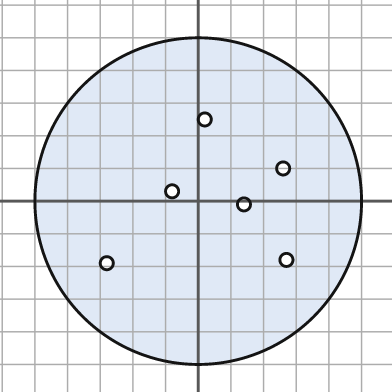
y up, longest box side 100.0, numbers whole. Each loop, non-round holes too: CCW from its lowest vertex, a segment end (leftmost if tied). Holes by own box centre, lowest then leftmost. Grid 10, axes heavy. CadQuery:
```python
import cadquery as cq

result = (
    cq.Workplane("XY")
    .moveTo(0.0, 0.0)
    .circle(50.0)
    .moveTo(-28.0, -19.0)
    .circle(2.0)
    .moveTo(27.0, -18.0)
    .circle(2.0)
    .moveTo(14.0, -1.0)
    .circle(2.0)
    .moveTo(-8.0, 3.0)
    .circle(2.0)
    .moveTo(26.0, 10.0)
    .circle(2.0)
    .moveTo(2.0, 25.0)
    .circle(2.0)
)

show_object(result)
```